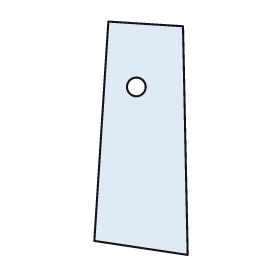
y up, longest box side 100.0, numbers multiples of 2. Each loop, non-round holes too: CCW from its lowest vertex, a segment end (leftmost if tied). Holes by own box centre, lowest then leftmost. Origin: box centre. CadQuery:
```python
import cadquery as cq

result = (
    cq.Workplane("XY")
    .moveTo(20.0, -50.0)
    .lineTo(18.0, 48.0)
    .lineTo(-14.0, 50.0)
    .lineTo(-20.0, -44.0)
    .close()
    .moveTo(-2.0, 22.0)
    .circle(4.0)
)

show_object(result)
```